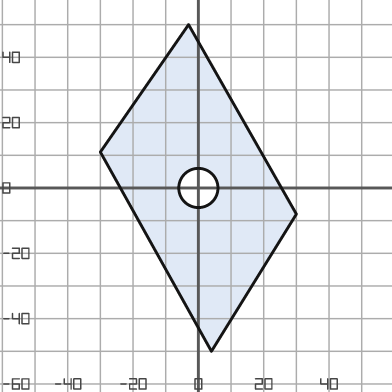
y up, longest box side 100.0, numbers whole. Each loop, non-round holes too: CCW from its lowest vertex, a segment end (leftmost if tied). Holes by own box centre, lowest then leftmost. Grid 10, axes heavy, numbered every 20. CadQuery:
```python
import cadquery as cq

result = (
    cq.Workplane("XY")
    .moveTo(4.0, -50.0)
    .lineTo(30.0, -8.0)
    .lineTo(-3.0, 50.0)
    .lineTo(-30.0, 11.0)
    .close()
    .moveTo(0.0, 0.0)
    .circle(6.0)
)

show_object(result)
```